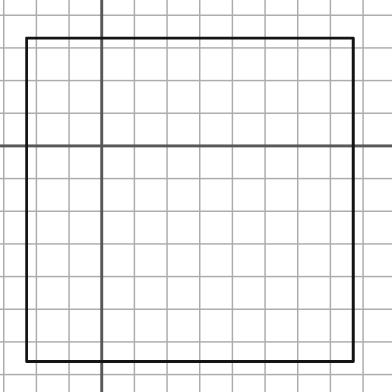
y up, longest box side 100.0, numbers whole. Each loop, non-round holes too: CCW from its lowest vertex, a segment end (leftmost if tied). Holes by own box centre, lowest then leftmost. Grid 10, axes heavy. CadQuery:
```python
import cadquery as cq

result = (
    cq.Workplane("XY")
    .moveTo(-23.0, -66.0)
    .lineTo(77.0, -66.0)
    .lineTo(77.0, 33.0)
    .lineTo(-23.0, 33.0)
    .close()
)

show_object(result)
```